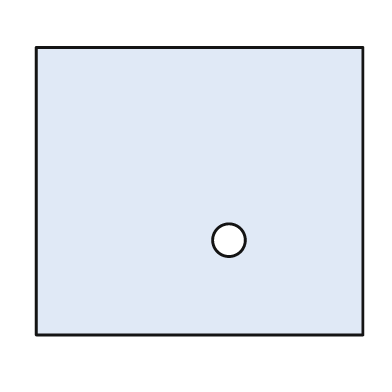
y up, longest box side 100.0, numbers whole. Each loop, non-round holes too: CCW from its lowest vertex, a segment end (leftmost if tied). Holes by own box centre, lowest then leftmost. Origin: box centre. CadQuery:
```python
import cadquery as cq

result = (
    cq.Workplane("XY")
    .moveTo(-50.0, -44.0)
    .lineTo(50.0, -44.0)
    .lineTo(50.0, 44.0)
    .lineTo(-50.0, 44.0)
    .close()
    .moveTo(9.0, -15.0)
    .circle(5.0)
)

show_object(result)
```